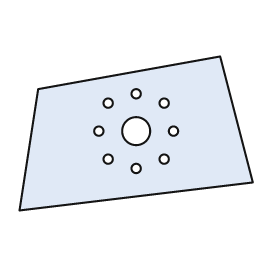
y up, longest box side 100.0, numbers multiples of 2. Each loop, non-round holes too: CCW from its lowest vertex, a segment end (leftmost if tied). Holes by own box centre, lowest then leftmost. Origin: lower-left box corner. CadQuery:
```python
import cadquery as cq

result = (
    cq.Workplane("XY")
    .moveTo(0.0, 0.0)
    .lineTo(100.0, 12.0)
    .lineTo(86.0, 66.0)
    .lineTo(8.0, 52.0)
    .close()
    .moveTo(50.0, 18.0)
    .circle(2.0)
    .moveTo(38.0, 22.0)
    .circle(2.0)
    .moveTo(62.0, 22.0)
    .circle(2.0)
    .moveTo(34.0, 34.0)
    .circle(2.0)
    .moveTo(50.0, 34.0)
    .circle(6.0)
    .moveTo(66.0, 34.0)
    .circle(2.0)
    .moveTo(38.0, 46.0)
    .circle(2.0)
    .moveTo(62.0, 46.0)
    .circle(2.0)
    .moveTo(50.0, 50.0)
    .circle(2.0)
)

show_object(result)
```